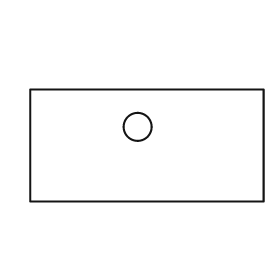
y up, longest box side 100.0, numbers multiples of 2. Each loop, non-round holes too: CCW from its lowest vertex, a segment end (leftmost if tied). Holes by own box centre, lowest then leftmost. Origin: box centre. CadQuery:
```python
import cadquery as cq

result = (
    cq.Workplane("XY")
    .moveTo(-50.0, -24.0)
    .lineTo(50.0, -24.0)
    .lineTo(50.0, 24.0)
    .lineTo(-50.0, 24.0)
    .close()
    .moveTo(-4.0, 8.0)
    .circle(6.0)
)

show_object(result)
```